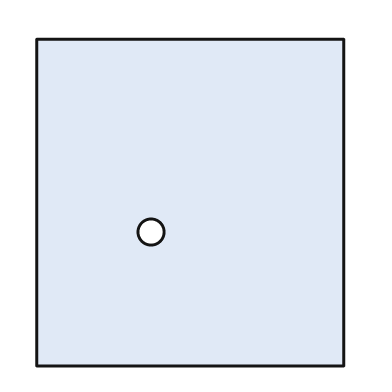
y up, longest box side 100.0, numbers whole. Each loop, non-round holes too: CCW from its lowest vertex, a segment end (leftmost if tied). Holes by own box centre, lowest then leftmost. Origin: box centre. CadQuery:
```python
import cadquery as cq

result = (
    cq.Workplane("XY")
    .moveTo(-47.0, -50.0)
    .lineTo(47.0, -50.0)
    .lineTo(47.0, 50.0)
    .lineTo(-47.0, 50.0)
    .close()
    .moveTo(-12.0, -9.0)
    .circle(4.0)
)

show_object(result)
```